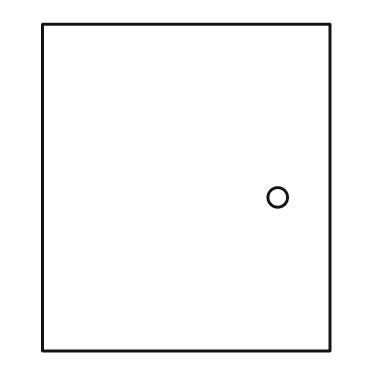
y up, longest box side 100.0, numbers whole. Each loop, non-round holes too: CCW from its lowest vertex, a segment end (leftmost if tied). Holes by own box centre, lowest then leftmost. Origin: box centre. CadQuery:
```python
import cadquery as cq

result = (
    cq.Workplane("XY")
    .moveTo(-44.0, -50.0)
    .lineTo(44.0, -50.0)
    .lineTo(44.0, 50.0)
    .lineTo(-44.0, 50.0)
    .close()
    .moveTo(28.0, -3.0)
    .circle(3.0)
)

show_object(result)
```